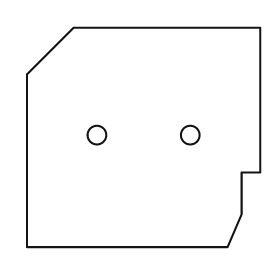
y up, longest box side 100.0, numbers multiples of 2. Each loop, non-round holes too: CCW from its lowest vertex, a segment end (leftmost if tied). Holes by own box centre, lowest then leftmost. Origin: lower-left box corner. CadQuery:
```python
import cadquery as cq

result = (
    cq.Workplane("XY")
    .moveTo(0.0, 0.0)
    .lineTo(86.0, 0.0)
    .lineTo(92.0, 14.0)
    .lineTo(92.0, 32.0)
    .lineTo(100.0, 32.0)
    .lineTo(100.0, 94.0)
    .lineTo(20.0, 94.0)
    .lineTo(0.0, 74.0)
    .close()
    .moveTo(30.0, 48.0)
    .circle(4.0)
    .moveTo(70.0, 48.0)
    .circle(4.0)
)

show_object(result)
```